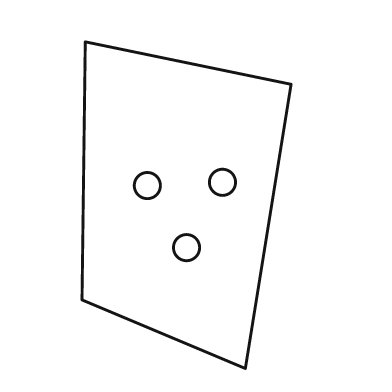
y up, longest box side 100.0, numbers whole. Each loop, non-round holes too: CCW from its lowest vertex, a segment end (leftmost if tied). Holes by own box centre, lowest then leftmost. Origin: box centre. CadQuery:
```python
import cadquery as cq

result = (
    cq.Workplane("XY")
    .moveTo(18.0, -50.0)
    .lineTo(32.0, 37.0)
    .lineTo(-31.0, 50.0)
    .lineTo(-32.0, -29.0)
    .close()
    .moveTo(0.0, -13.0)
    .circle(4.0)
    .moveTo(-12.0, 6.0)
    .circle(4.0)
    .moveTo(11.0, 7.0)
    .circle(4.0)
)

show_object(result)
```